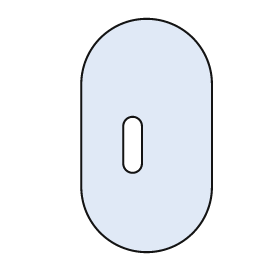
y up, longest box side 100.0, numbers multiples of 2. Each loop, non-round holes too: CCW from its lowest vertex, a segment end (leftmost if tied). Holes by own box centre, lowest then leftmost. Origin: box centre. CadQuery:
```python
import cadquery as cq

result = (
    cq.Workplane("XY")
    .moveTo(-28.0, -22.0)
    .threePointArc((0.0, -50.0), (28.0, -22.0))
    .lineTo(28.0, 22.0)
    .threePointArc((0.0, 50.0), (-28.0, 22.0))
    .close()
    .moveTo(-10.0, -12.0)
    .threePointArc((-6.0, -16.0), (-2.0, -12.0))
    .lineTo(-2.0, 4.0)
    .threePointArc((-6.0, 8.0), (-10.0, 4.0))
    .close()
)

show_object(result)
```